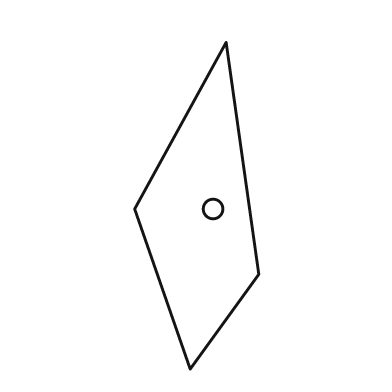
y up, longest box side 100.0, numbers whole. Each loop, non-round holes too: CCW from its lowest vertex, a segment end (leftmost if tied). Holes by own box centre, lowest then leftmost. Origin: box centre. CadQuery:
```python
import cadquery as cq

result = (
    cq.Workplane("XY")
    .moveTo(-2.0, -50.0)
    .lineTo(19.0, -21.0)
    .lineTo(9.0, 50.0)
    .lineTo(-19.0, -1.0)
    .close()
    .moveTo(5.0, -1.0)
    .circle(3.0)
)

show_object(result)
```